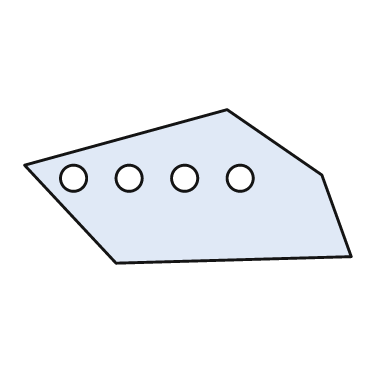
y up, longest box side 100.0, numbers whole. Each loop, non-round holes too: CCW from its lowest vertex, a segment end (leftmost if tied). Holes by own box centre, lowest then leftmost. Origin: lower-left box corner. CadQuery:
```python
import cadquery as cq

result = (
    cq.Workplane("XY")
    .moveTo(28.0, 0.0)
    .lineTo(100.0, 2.0)
    .lineTo(91.0, 27.0)
    .lineTo(62.0, 47.0)
    .lineTo(0.0, 30.0)
    .close()
    .moveTo(15.0, 26.0)
    .circle(4.0)
    .moveTo(32.0, 26.0)
    .circle(4.0)
    .moveTo(49.0, 26.0)
    .circle(4.0)
    .moveTo(66.0, 26.0)
    .circle(4.0)
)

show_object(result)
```